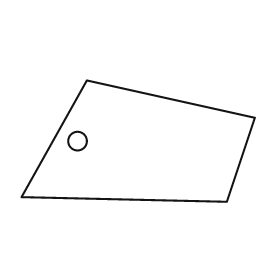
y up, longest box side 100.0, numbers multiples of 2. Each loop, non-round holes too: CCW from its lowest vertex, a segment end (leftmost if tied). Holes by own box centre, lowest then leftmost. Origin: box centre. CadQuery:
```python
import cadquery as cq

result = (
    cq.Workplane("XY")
    .moveTo(38.0, -26.0)
    .lineTo(50.0, 10.0)
    .lineTo(-22.0, 26.0)
    .lineTo(-50.0, -24.0)
    .close()
    .moveTo(-26.0, 0.0)
    .circle(4.0)
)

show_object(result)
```